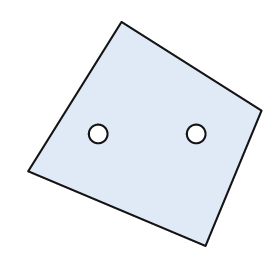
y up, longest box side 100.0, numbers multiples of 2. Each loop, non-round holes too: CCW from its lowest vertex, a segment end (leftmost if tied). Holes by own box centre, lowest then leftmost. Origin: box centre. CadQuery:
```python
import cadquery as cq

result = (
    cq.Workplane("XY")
    .moveTo(26.0, -48.0)
    .lineTo(50.0, 10.0)
    .lineTo(-10.0, 48.0)
    .lineTo(-50.0, -16.0)
    .close()
    .moveTo(-20.0, 0.0)
    .circle(4.0)
    .moveTo(22.0, 0.0)
    .circle(4.0)
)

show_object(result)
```